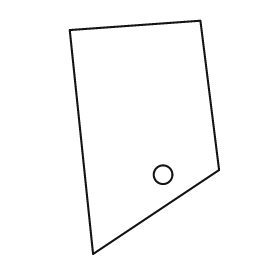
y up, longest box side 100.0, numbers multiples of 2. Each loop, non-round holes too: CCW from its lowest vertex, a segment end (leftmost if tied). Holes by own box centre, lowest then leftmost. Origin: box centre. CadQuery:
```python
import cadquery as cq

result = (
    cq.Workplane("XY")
    .moveTo(-22.0, -50.0)
    .lineTo(32.0, -14.0)
    .lineTo(24.0, 50.0)
    .lineTo(-32.0, 46.0)
    .close()
    .moveTo(8.0, -16.0)
    .circle(4.0)
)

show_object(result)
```